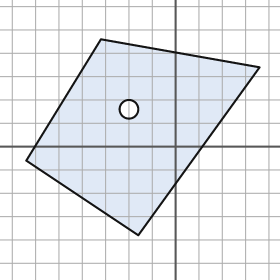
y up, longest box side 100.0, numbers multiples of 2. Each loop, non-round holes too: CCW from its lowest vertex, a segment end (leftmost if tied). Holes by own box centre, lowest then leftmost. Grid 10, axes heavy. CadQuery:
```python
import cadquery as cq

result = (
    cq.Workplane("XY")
    .moveTo(-16.0, -38.0)
    .lineTo(36.0, 34.0)
    .lineTo(-32.0, 46.0)
    .lineTo(-64.0, -6.0)
    .close()
    .moveTo(-20.0, 16.0)
    .circle(4.0)
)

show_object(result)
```